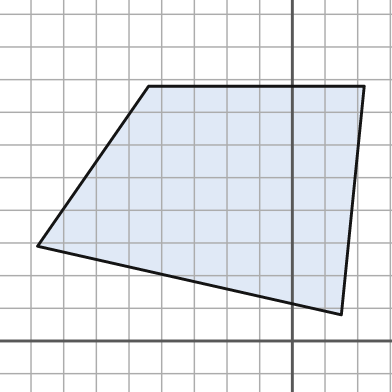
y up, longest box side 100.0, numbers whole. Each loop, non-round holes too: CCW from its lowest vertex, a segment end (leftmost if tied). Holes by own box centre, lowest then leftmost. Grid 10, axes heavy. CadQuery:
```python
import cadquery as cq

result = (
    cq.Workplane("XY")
    .moveTo(15.0, 8.0)
    .lineTo(22.0, 78.0)
    .lineTo(-44.0, 78.0)
    .lineTo(-78.0, 29.0)
    .close()
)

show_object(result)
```